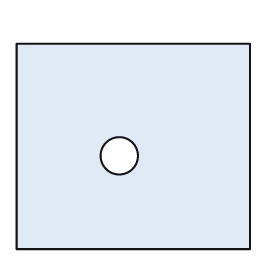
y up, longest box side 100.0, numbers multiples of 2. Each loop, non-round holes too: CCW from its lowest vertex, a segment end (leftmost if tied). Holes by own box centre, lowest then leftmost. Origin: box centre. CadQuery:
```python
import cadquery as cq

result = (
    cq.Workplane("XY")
    .moveTo(-50.0, -44.0)
    .lineTo(50.0, -44.0)
    .lineTo(50.0, 44.0)
    .lineTo(-50.0, 44.0)
    .close()
    .moveTo(-6.0, -4.0)
    .circle(8.0)
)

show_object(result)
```